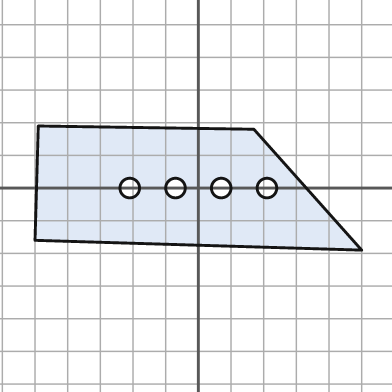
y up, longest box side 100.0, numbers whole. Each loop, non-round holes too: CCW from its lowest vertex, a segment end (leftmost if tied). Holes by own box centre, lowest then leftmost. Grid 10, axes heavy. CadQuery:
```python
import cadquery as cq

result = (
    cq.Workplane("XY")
    .moveTo(50.0, -19.0)
    .lineTo(17.0, 18.0)
    .lineTo(-49.0, 19.0)
    .lineTo(-50.0, -16.0)
    .close()
    .moveTo(-21.0, 0.0)
    .circle(3.0)
    .moveTo(-7.0, 0.0)
    .circle(3.0)
    .moveTo(7.0, 0.0)
    .circle(3.0)
    .moveTo(21.0, 0.0)
    .circle(3.0)
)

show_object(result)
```